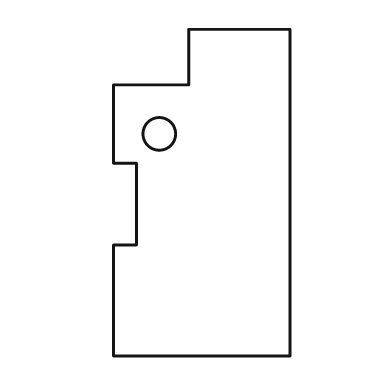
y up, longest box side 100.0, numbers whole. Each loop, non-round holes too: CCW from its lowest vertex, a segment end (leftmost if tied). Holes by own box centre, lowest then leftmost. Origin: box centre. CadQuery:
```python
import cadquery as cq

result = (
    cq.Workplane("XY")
    .moveTo(-27.0, -50.0)
    .lineTo(27.0, -50.0)
    .lineTo(27.0, 50.0)
    .lineTo(-4.0, 50.0)
    .lineTo(-4.0, 33.0)
    .lineTo(-27.0, 33.0)
    .lineTo(-27.0, 9.0)
    .lineTo(-20.0, 9.0)
    .lineTo(-20.0, -16.0)
    .lineTo(-27.0, -16.0)
    .close()
    .moveTo(-13.0, 18.0)
    .circle(5.0)
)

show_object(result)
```